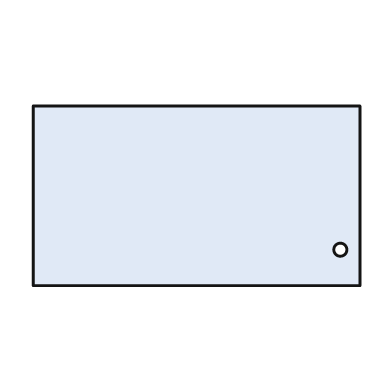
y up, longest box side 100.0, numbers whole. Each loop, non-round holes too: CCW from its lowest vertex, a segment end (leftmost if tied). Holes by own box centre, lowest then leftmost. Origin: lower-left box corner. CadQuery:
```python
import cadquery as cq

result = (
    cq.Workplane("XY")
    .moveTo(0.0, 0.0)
    .lineTo(100.0, 0.0)
    .lineTo(100.0, 55.0)
    .lineTo(0.0, 55.0)
    .close()
    .moveTo(94.0, 11.0)
    .circle(2.0)
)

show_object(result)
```